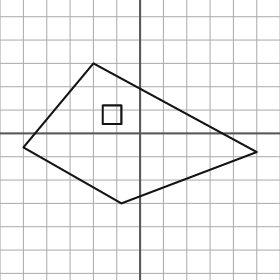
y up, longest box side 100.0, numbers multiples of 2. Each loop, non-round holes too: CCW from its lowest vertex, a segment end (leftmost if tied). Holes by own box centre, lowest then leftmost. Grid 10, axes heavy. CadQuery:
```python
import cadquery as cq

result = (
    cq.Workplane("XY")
    .moveTo(-8.0, -30.0)
    .lineTo(50.0, -8.0)
    .lineTo(-20.0, 30.0)
    .lineTo(-50.0, -6.0)
    .close()
    .moveTo(-16.0, 4.0)
    .lineTo(-8.0, 4.0)
    .lineTo(-8.0, 12.0)
    .lineTo(-16.0, 12.0)
    .close()
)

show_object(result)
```